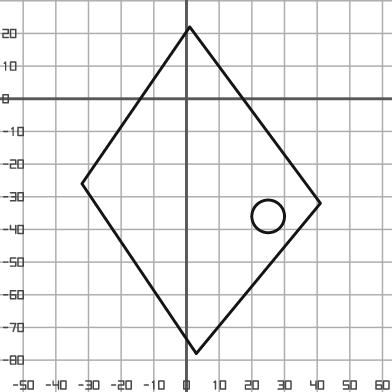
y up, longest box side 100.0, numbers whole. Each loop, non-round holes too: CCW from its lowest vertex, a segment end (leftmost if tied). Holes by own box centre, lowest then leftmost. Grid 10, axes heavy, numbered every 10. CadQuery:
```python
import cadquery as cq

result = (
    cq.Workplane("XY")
    .moveTo(3.0, -78.0)
    .lineTo(41.0, -32.0)
    .lineTo(1.0, 22.0)
    .lineTo(-32.0, -26.0)
    .close()
    .moveTo(25.0, -36.0)
    .circle(5.0)
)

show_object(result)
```